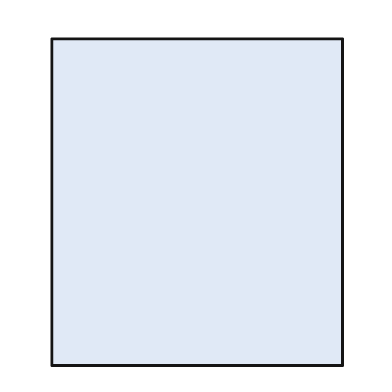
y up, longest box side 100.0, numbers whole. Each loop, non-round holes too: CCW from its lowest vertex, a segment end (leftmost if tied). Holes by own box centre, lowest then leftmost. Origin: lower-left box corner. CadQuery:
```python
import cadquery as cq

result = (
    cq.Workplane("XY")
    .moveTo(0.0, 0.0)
    .lineTo(89.0, 0.0)
    .lineTo(89.0, 100.0)
    .lineTo(0.0, 100.0)
    .close()
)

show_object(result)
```